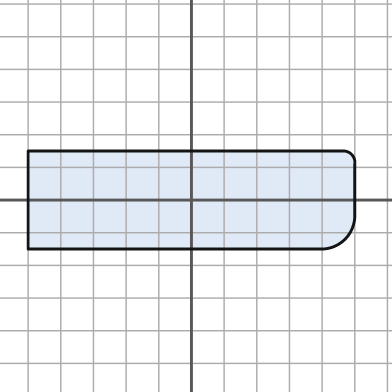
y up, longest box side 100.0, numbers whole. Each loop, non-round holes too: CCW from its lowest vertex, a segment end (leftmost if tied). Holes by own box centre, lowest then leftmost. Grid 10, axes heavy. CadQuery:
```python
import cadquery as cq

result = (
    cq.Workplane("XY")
    .moveTo(-50.0, -15.0)
    .lineTo(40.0, -15.0)
    .threePointArc((47.0, -12.0), (50.0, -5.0))
    .lineTo(50.0, 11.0)
    .threePointArc((49.0, 14.0), (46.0, 15.0))
    .lineTo(-50.0, 15.0)
    .close()
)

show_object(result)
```